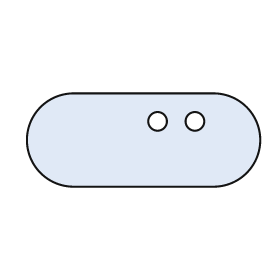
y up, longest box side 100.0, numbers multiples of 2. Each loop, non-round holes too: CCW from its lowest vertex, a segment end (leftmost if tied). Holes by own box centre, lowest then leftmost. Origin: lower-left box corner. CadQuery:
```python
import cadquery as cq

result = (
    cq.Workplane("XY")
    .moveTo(20.0, 0.0)
    .lineTo(80.0, 0.0)
    .threePointArc((100.0, 20.0), (80.0, 40.0))
    .lineTo(20.0, 40.0)
    .threePointArc((0.0, 20.0), (20.0, 0.0))
    .close()
    .moveTo(56.0, 28.0)
    .circle(4.0)
    .moveTo(72.0, 28.0)
    .circle(4.0)
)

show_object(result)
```